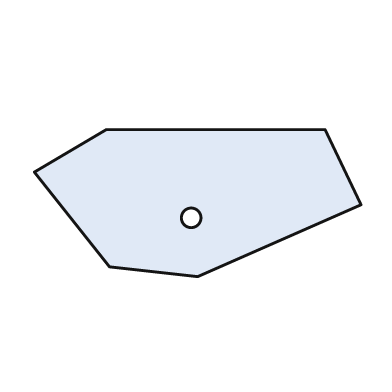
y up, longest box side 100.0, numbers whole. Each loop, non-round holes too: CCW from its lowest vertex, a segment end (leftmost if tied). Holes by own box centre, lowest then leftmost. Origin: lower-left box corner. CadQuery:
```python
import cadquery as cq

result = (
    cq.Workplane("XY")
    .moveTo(50.0, 0.0)
    .lineTo(100.0, 22.0)
    .lineTo(89.0, 45.0)
    .lineTo(22.0, 45.0)
    .lineTo(0.0, 32.0)
    .lineTo(23.0, 3.0)
    .close()
    .moveTo(48.0, 18.0)
    .circle(3.0)
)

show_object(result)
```